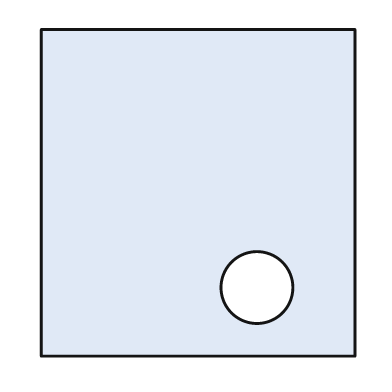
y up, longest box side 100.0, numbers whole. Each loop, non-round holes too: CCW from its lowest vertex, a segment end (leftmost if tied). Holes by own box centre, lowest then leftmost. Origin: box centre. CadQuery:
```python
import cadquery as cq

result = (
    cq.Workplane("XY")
    .moveTo(-48.0, -50.0)
    .lineTo(48.0, -50.0)
    .lineTo(48.0, 50.0)
    .lineTo(-48.0, 50.0)
    .close()
    .moveTo(18.0, -29.0)
    .circle(11.0)
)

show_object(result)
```